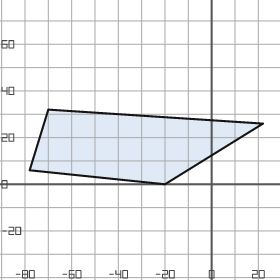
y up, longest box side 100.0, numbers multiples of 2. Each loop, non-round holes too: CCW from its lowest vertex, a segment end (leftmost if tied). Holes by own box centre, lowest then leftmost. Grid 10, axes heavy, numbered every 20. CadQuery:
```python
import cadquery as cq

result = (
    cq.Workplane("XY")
    .moveTo(-20.0, 0.0)
    .lineTo(22.0, 26.0)
    .lineTo(-70.0, 32.0)
    .lineTo(-78.0, 6.0)
    .close()
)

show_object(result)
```